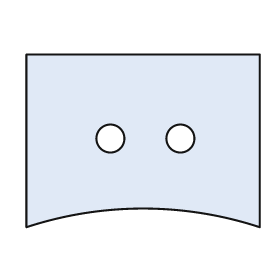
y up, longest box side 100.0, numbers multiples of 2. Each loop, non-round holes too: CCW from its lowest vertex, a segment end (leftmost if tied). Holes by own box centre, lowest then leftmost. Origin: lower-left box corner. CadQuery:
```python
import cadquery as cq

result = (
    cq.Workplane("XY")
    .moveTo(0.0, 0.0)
    .threePointArc((50.0, 8.0), (100.0, 0.0))
    .lineTo(100.0, 74.0)
    .lineTo(0.0, 74.0)
    .close()
    .moveTo(36.0, 38.0)
    .circle(6.0)
    .moveTo(66.0, 38.0)
    .circle(6.0)
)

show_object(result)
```